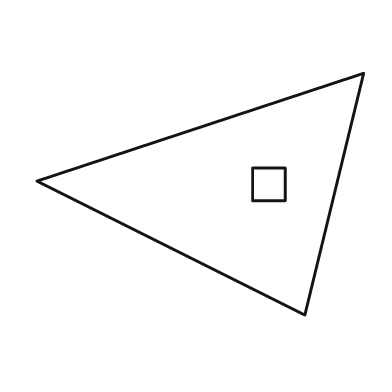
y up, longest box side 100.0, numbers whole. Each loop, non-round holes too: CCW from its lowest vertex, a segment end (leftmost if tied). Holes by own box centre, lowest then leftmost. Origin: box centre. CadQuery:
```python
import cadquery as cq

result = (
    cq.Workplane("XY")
    .moveTo(32.0, -37.0)
    .lineTo(50.0, 37.0)
    .lineTo(-50.0, 4.0)
    .close()
    .moveTo(16.0, -2.0)
    .lineTo(26.0, -2.0)
    .lineTo(26.0, 8.0)
    .lineTo(16.0, 8.0)
    .close()
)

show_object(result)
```